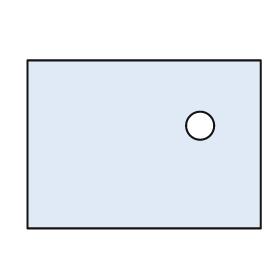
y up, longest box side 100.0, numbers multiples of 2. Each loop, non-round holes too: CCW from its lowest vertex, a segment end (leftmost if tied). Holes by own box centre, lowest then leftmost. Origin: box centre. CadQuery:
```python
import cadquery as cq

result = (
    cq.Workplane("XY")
    .moveTo(-50.0, -36.0)
    .lineTo(50.0, -36.0)
    .lineTo(50.0, 36.0)
    .lineTo(-50.0, 36.0)
    .close()
    .moveTo(24.0, 8.0)
    .circle(6.0)
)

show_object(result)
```